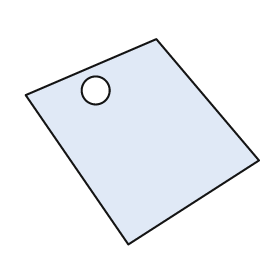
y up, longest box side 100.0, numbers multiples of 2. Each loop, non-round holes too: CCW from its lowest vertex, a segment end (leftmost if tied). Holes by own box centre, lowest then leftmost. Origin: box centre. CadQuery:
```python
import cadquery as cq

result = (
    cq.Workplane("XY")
    .moveTo(-6.0, -44.0)
    .lineTo(50.0, -8.0)
    .lineTo(6.0, 44.0)
    .lineTo(-50.0, 20.0)
    .close()
    .moveTo(-20.0, 22.0)
    .circle(6.0)
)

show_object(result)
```